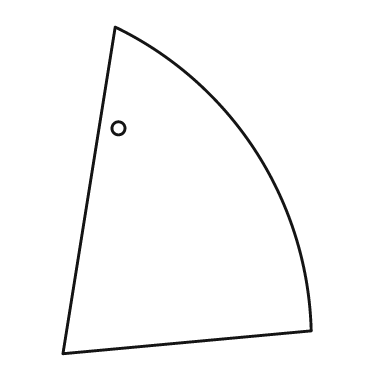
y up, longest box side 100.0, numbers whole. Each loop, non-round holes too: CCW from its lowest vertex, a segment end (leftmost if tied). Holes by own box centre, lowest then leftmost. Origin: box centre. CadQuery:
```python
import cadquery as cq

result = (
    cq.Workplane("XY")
    .moveTo(-38.0, -50.0)
    .lineTo(38.0, -43.0)
    .threePointArc((21.0, 12.0), (-22.0, 50.0))
    .close()
    .moveTo(-21.0, 19.0)
    .circle(2.0)
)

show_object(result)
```